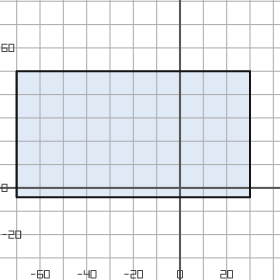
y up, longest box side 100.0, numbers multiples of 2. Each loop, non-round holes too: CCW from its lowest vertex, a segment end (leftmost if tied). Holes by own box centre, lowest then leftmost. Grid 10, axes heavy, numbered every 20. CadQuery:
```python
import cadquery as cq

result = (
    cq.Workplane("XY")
    .moveTo(-70.0, -4.0)
    .lineTo(30.0, -4.0)
    .lineTo(30.0, 50.0)
    .lineTo(-70.0, 50.0)
    .close()
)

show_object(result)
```